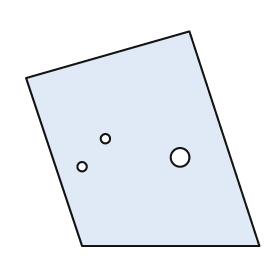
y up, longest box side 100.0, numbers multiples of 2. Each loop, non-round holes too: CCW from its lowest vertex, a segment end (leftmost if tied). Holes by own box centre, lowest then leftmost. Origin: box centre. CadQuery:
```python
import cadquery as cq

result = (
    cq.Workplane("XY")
    .moveTo(-26.0, -46.0)
    .lineTo(50.0, -46.0)
    .lineTo(20.0, 46.0)
    .lineTo(-50.0, 26.0)
    .close()
    .moveTo(-26.0, -12.0)
    .circle(2.0)
    .moveTo(16.0, -8.0)
    .circle(4.0)
    .moveTo(-16.0, 0.0)
    .circle(2.0)
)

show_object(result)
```